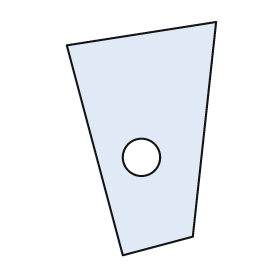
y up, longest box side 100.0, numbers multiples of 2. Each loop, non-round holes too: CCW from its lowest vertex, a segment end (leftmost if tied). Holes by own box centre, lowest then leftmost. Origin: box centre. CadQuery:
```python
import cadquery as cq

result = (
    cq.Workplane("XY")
    .moveTo(-8.0, -50.0)
    .lineTo(22.0, -42.0)
    .lineTo(32.0, 50.0)
    .lineTo(-32.0, 40.0)
    .close()
    .moveTo(0.0, -8.0)
    .circle(8.0)
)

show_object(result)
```